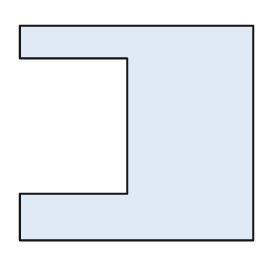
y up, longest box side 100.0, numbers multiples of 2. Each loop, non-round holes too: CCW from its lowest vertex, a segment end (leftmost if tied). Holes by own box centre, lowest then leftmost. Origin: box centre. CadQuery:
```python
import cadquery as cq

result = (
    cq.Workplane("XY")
    .moveTo(-50.0, -46.0)
    .lineTo(50.0, -46.0)
    .lineTo(50.0, 46.0)
    .lineTo(-50.0, 46.0)
    .lineTo(-50.0, 32.0)
    .lineTo(-4.0, 32.0)
    .lineTo(-4.0, -26.0)
    .lineTo(-50.0, -26.0)
    .close()
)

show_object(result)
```